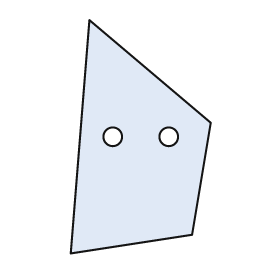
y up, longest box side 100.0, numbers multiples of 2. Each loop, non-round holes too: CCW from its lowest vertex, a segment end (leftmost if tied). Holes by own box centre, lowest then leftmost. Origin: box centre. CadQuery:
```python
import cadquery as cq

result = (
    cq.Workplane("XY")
    .moveTo(-30.0, -50.0)
    .lineTo(22.0, -42.0)
    .lineTo(30.0, 6.0)
    .lineTo(-22.0, 50.0)
    .close()
    .moveTo(-12.0, 0.0)
    .circle(4.0)
    .moveTo(12.0, 0.0)
    .circle(4.0)
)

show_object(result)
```